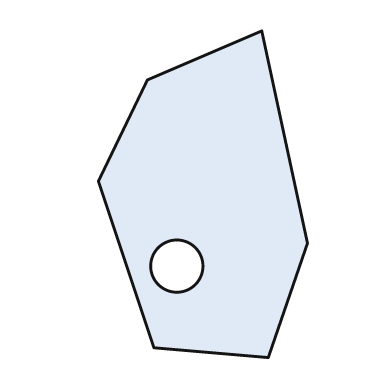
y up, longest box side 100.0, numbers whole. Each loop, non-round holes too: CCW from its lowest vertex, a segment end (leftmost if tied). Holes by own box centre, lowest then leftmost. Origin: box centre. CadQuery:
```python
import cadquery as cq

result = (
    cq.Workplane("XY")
    .moveTo(20.0, -50.0)
    .lineTo(32.0, -15.0)
    .lineTo(18.0, 50.0)
    .lineTo(-17.0, 35.0)
    .lineTo(-32.0, 4.0)
    .lineTo(-15.0, -47.0)
    .close()
    .moveTo(-8.0, -22.0)
    .circle(8.0)
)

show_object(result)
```